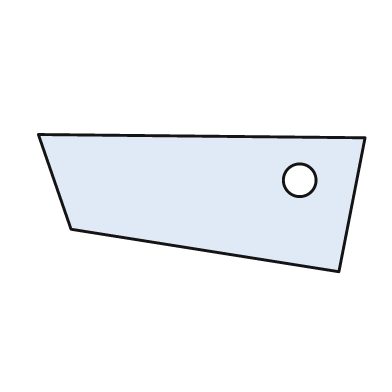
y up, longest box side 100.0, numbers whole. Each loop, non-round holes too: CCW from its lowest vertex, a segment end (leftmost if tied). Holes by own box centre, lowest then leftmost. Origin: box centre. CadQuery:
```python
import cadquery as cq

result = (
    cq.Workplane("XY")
    .moveTo(42.0, -21.0)
    .lineTo(50.0, 20.0)
    .lineTo(-50.0, 21.0)
    .lineTo(-40.0, -8.0)
    .close()
    .moveTo(30.0, 7.0)
    .circle(5.0)
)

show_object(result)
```